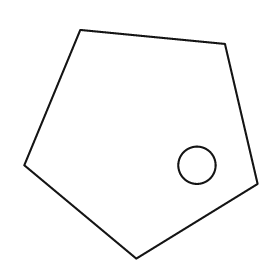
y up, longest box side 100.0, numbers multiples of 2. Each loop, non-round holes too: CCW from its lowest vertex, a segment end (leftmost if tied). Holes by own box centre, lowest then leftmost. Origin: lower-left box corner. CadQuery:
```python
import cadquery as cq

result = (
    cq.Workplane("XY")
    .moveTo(48.0, 0.0)
    .lineTo(100.0, 32.0)
    .lineTo(86.0, 92.0)
    .lineTo(24.0, 98.0)
    .lineTo(0.0, 40.0)
    .close()
    .moveTo(74.0, 40.0)
    .circle(8.0)
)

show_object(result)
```